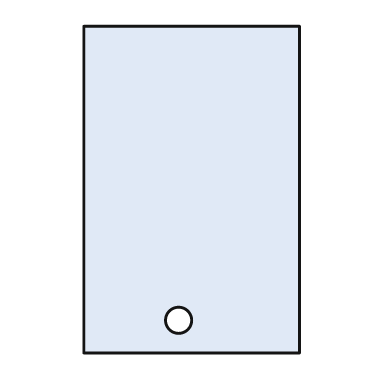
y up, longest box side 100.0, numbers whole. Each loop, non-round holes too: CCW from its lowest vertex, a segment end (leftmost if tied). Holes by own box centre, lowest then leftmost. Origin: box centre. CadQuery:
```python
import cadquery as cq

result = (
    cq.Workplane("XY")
    .moveTo(-33.0, -50.0)
    .lineTo(33.0, -50.0)
    .lineTo(33.0, 50.0)
    .lineTo(-33.0, 50.0)
    .close()
    .moveTo(-4.0, -40.0)
    .circle(4.0)
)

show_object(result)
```